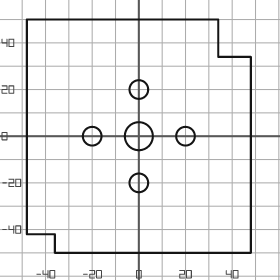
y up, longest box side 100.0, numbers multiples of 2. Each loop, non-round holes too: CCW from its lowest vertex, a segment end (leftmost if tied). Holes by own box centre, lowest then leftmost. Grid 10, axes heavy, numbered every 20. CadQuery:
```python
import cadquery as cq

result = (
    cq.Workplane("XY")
    .moveTo(-36.0, -50.0)
    .lineTo(48.0, -50.0)
    .lineTo(48.0, 34.0)
    .lineTo(34.0, 34.0)
    .lineTo(34.0, 50.0)
    .lineTo(-48.0, 50.0)
    .lineTo(-48.0, -42.0)
    .lineTo(-36.0, -42.0)
    .close()
    .moveTo(0.0, -20.0)
    .circle(4.0)
    .moveTo(-20.0, 0.0)
    .circle(4.0)
    .moveTo(0.0, 0.0)
    .circle(6.0)
    .moveTo(20.0, 0.0)
    .circle(4.0)
    .moveTo(0.0, 20.0)
    .circle(4.0)
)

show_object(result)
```